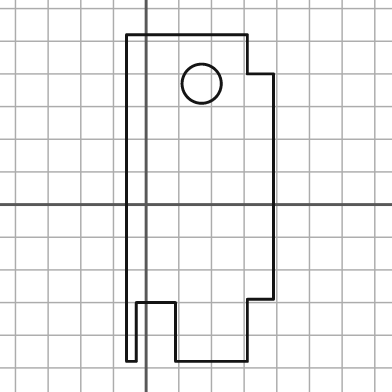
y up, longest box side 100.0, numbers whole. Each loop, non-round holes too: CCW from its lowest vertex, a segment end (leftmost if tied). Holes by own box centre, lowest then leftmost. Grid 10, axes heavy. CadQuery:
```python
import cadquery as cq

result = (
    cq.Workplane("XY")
    .moveTo(-6.0, -48.0)
    .lineTo(-3.0, -48.0)
    .lineTo(-3.0, -30.0)
    .lineTo(9.0, -30.0)
    .lineTo(9.0, -48.0)
    .lineTo(31.0, -48.0)
    .lineTo(31.0, -29.0)
    .lineTo(39.0, -29.0)
    .lineTo(39.0, 40.0)
    .lineTo(31.0, 40.0)
    .lineTo(31.0, 52.0)
    .lineTo(-6.0, 52.0)
    .close()
    .moveTo(17.0, 37.0)
    .circle(6.0)
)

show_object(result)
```